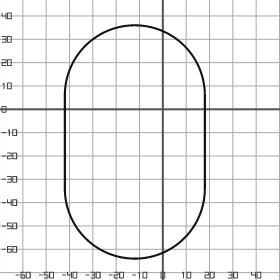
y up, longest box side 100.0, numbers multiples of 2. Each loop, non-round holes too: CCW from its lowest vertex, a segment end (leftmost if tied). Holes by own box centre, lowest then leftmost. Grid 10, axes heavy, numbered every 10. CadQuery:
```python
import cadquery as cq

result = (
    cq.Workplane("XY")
    .moveTo(-42.0, -34.0)
    .threePointArc((-12.0, -64.0), (18.0, -34.0))
    .lineTo(18.0, 6.0)
    .threePointArc((-12.0, 36.0), (-42.0, 6.0))
    .close()
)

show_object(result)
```